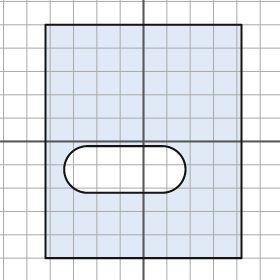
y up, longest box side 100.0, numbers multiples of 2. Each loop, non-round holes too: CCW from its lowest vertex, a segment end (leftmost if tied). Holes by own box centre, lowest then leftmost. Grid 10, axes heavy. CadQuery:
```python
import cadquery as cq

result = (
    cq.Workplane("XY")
    .moveTo(-42.0, -50.0)
    .lineTo(42.0, -50.0)
    .lineTo(42.0, 50.0)
    .lineTo(-42.0, 50.0)
    .close()
    .moveTo(-24.0, -22.0)
    .lineTo(8.0, -22.0)
    .threePointArc((18.0, -12.0), (8.0, -2.0))
    .lineTo(-24.0, -2.0)
    .threePointArc((-34.0, -12.0), (-24.0, -22.0))
    .close()
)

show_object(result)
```